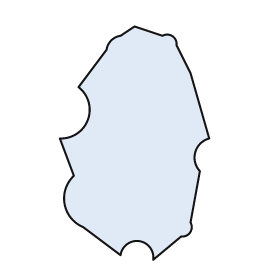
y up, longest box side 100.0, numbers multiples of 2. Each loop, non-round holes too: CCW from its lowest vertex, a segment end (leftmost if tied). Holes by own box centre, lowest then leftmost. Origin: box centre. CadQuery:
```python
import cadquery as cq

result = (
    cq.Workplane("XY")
    .moveTo(8.0, -50.0)
    .lineTo(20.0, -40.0)
    .threePointArc((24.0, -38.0), (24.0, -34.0))
    .lineTo(28.0, -12.0)
    .threePointArc((26.0, -4.0), (32.0, 2.0))
    .lineTo(24.0, 30.0)
    .lineTo(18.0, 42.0)
    .threePointArc((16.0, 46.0), (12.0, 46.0))
    .lineTo(0.0, 50.0)
    .lineTo(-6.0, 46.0)
    .threePointArc((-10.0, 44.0), (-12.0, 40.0))
    .lineTo(-24.0, 24.0)
    .threePointArc((-20.0, 10.0), (-32.0, 2.0))
    .lineTo(-26.0, -14.0)
    .threePointArc((-30.0, -26.0), (-22.0, -36.0))
    .lineTo(-6.0, -48.0)
    .threePointArc((2.0, -42.0), (8.0, -50.0))
    .close()
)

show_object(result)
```